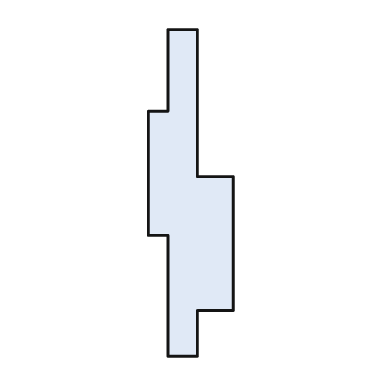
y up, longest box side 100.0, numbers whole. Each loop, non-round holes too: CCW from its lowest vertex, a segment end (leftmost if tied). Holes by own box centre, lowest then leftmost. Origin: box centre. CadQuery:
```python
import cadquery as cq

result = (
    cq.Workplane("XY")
    .moveTo(-7.0, -50.0)
    .lineTo(2.0, -50.0)
    .lineTo(2.0, -36.0)
    .lineTo(13.0, -36.0)
    .lineTo(13.0, 5.0)
    .lineTo(2.0, 5.0)
    .lineTo(2.0, 50.0)
    .lineTo(-7.0, 50.0)
    .lineTo(-7.0, 25.0)
    .lineTo(-13.0, 25.0)
    .lineTo(-13.0, -13.0)
    .lineTo(-7.0, -13.0)
    .close()
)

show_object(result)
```